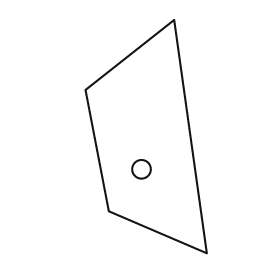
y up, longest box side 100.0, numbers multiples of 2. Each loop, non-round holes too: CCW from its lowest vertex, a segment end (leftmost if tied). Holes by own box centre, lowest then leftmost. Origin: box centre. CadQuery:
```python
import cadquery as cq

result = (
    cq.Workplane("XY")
    .moveTo(26.0, -50.0)
    .lineTo(12.0, 50.0)
    .lineTo(-26.0, 20.0)
    .lineTo(-16.0, -32.0)
    .close()
    .moveTo(-2.0, -14.0)
    .circle(4.0)
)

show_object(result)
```